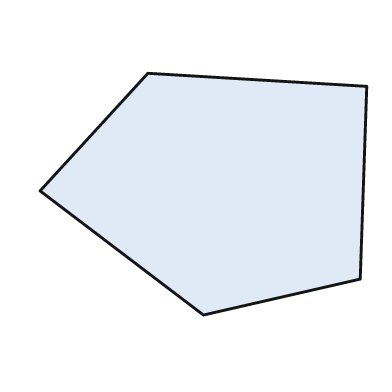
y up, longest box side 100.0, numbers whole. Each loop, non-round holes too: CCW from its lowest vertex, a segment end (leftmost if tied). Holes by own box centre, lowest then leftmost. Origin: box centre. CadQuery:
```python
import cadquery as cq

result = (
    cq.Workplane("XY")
    .moveTo(0.0, -37.0)
    .lineTo(48.0, -26.0)
    .lineTo(50.0, 33.0)
    .lineTo(-17.0, 37.0)
    .lineTo(-50.0, 1.0)
    .close()
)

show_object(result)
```